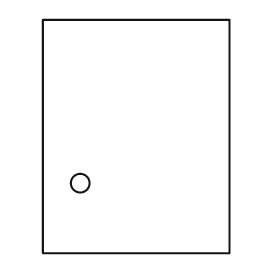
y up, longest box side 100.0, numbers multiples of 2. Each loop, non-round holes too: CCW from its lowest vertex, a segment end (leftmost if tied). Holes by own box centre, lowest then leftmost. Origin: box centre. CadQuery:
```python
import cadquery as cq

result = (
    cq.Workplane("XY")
    .moveTo(-40.0, -50.0)
    .lineTo(40.0, -50.0)
    .lineTo(40.0, 50.0)
    .lineTo(-40.0, 50.0)
    .close()
    .moveTo(-24.0, -20.0)
    .circle(4.0)
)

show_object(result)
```